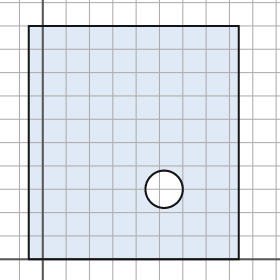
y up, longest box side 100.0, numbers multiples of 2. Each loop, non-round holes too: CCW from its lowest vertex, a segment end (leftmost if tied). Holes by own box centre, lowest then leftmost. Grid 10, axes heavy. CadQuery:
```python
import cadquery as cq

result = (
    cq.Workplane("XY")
    .moveTo(-6.0, 0.0)
    .lineTo(84.0, 0.0)
    .lineTo(84.0, 100.0)
    .lineTo(-6.0, 100.0)
    .close()
    .moveTo(52.0, 30.0)
    .circle(8.0)
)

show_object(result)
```